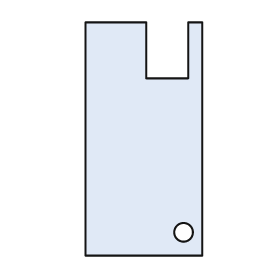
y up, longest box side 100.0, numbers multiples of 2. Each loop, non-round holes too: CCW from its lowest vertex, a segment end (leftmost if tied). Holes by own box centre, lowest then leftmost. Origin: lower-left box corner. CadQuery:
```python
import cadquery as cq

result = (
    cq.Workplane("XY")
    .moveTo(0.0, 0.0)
    .lineTo(50.0, 0.0)
    .lineTo(50.0, 100.0)
    .lineTo(44.0, 100.0)
    .lineTo(44.0, 76.0)
    .lineTo(26.0, 76.0)
    .lineTo(26.0, 100.0)
    .lineTo(0.0, 100.0)
    .close()
    .moveTo(42.0, 10.0)
    .circle(4.0)
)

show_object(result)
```